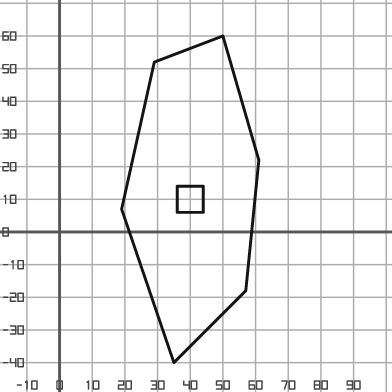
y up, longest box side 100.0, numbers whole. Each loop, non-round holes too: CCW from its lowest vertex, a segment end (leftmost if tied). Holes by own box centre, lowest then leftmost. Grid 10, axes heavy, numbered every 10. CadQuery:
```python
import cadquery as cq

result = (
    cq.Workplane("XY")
    .moveTo(35.0, -40.0)
    .lineTo(57.0, -18.0)
    .lineTo(61.0, 22.0)
    .lineTo(50.0, 60.0)
    .lineTo(29.0, 52.0)
    .lineTo(19.0, 7.0)
    .close()
    .moveTo(36.0, 6.0)
    .lineTo(44.0, 6.0)
    .lineTo(44.0, 14.0)
    .lineTo(36.0, 14.0)
    .close()
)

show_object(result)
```